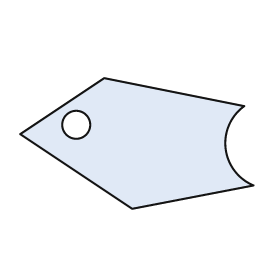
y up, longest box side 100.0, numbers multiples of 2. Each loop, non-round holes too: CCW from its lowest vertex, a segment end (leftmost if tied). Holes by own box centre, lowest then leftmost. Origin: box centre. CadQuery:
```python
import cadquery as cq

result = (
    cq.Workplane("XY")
    .moveTo(-2.0, -28.0)
    .lineTo(50.0, -18.0)
    .threePointArc((38.0, -2.0), (46.0, 16.0))
    .lineTo(-14.0, 28.0)
    .lineTo(-50.0, 4.0)
    .close()
    .moveTo(-26.0, 8.0)
    .circle(6.0)
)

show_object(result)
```